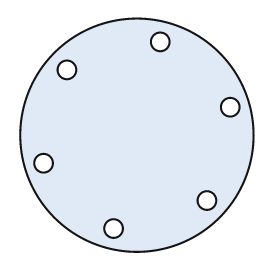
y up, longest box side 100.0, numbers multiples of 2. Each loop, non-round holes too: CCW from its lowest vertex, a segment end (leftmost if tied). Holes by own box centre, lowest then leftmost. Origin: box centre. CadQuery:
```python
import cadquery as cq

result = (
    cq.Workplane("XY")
    .moveTo(0.0, 0.0)
    .circle(50.0)
    .moveTo(-10.0, -40.0)
    .circle(4.0)
    .moveTo(30.0, -28.0)
    .circle(4.0)
    .moveTo(-40.0, -12.0)
    .circle(4.0)
    .moveTo(40.0, 12.0)
    .circle(4.0)
    .moveTo(-30.0, 28.0)
    .circle(4.0)
    .moveTo(10.0, 40.0)
    .circle(4.0)
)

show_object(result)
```